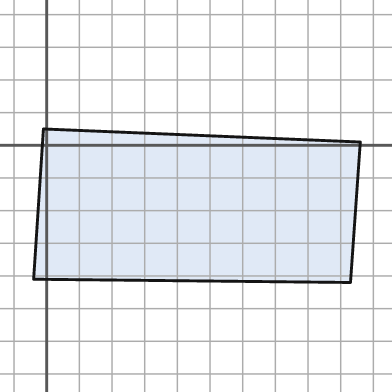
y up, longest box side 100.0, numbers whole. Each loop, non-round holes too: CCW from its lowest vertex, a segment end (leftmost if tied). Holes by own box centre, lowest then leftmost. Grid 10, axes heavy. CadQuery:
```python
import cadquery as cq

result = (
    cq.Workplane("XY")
    .moveTo(93.0, -42.0)
    .lineTo(96.0, 1.0)
    .lineTo(-1.0, 5.0)
    .lineTo(-4.0, -41.0)
    .close()
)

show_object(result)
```